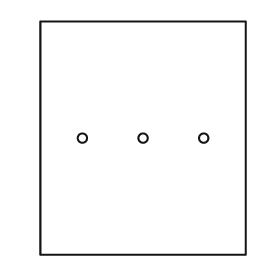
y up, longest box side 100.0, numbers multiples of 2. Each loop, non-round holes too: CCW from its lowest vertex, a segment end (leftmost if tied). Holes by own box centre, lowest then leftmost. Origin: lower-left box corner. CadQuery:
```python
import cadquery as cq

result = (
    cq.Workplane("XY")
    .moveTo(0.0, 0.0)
    .lineTo(88.0, 0.0)
    .lineTo(88.0, 100.0)
    .lineTo(0.0, 100.0)
    .close()
    .moveTo(18.0, 50.0)
    .circle(2.0)
    .moveTo(44.0, 50.0)
    .circle(2.0)
    .moveTo(70.0, 50.0)
    .circle(2.0)
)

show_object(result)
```